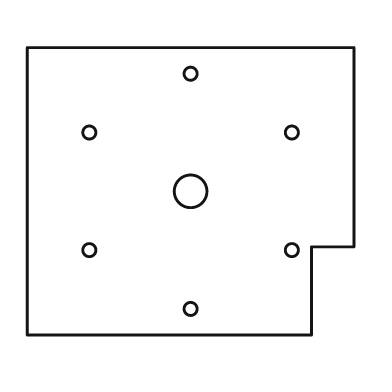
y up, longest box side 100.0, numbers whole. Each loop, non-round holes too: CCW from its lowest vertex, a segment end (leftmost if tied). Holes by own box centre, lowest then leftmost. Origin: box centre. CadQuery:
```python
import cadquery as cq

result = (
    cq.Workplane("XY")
    .moveTo(-50.0, -44.0)
    .lineTo(37.0, -44.0)
    .lineTo(37.0, -17.0)
    .lineTo(50.0, -17.0)
    .lineTo(50.0, 44.0)
    .lineTo(-50.0, 44.0)
    .close()
    .moveTo(0.0, -36.0)
    .circle(2.0)
    .moveTo(-31.0, -18.0)
    .circle(2.0)
    .moveTo(31.0, -18.0)
    .circle(2.0)
    .moveTo(0.0, 0.0)
    .circle(5.0)
    .moveTo(-31.0, 18.0)
    .circle(2.0)
    .moveTo(31.0, 18.0)
    .circle(2.0)
    .moveTo(0.0, 36.0)
    .circle(2.0)
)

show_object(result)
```